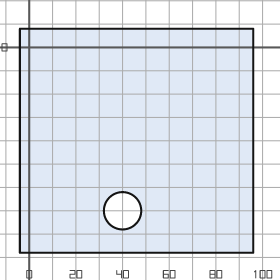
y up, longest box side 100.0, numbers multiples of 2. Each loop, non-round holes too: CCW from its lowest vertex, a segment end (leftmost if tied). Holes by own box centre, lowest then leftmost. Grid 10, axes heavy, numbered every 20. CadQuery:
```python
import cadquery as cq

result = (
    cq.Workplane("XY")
    .moveTo(-4.0, -88.0)
    .lineTo(96.0, -88.0)
    .lineTo(96.0, 8.0)
    .lineTo(-4.0, 8.0)
    .close()
    .moveTo(40.0, -70.0)
    .circle(8.0)
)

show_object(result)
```